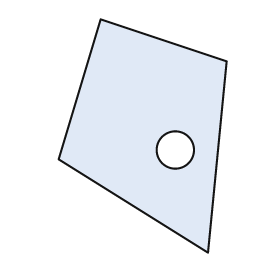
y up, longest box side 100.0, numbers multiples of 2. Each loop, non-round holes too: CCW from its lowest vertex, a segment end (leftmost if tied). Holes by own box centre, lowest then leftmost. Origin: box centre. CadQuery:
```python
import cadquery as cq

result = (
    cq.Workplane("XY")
    .moveTo(28.0, -50.0)
    .lineTo(36.0, 32.0)
    .lineTo(-18.0, 50.0)
    .lineTo(-36.0, -10.0)
    .close()
    .moveTo(14.0, -6.0)
    .circle(8.0)
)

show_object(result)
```